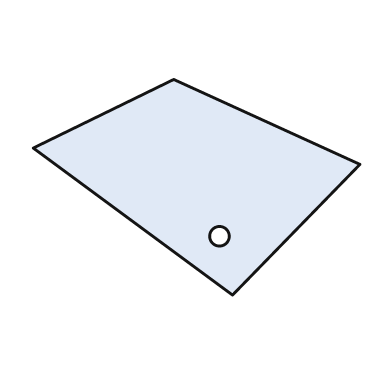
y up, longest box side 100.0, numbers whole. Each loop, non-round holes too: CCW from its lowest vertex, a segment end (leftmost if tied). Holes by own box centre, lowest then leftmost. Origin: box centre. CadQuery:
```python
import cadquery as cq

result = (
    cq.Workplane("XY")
    .moveTo(11.0, -33.0)
    .lineTo(50.0, 7.0)
    .lineTo(-7.0, 33.0)
    .lineTo(-50.0, 12.0)
    .close()
    .moveTo(7.0, -15.0)
    .circle(3.0)
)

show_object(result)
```